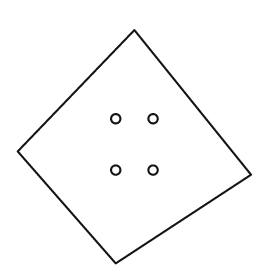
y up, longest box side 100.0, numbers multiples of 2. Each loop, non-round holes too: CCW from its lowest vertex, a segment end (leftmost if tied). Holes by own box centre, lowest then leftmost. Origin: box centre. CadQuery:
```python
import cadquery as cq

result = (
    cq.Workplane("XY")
    .moveTo(-8.0, -50.0)
    .lineTo(50.0, -12.0)
    .lineTo(0.0, 50.0)
    .lineTo(-50.0, -2.0)
    .close()
    .moveTo(-8.0, -10.0)
    .circle(2.0)
    .moveTo(8.0, -10.0)
    .circle(2.0)
    .moveTo(-8.0, 12.0)
    .circle(2.0)
    .moveTo(8.0, 12.0)
    .circle(2.0)
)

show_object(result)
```